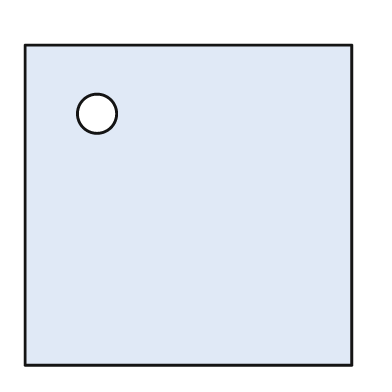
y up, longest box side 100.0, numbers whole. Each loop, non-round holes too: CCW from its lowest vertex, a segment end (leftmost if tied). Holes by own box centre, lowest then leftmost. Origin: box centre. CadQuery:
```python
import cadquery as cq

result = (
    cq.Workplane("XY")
    .moveTo(-50.0, -49.0)
    .lineTo(50.0, -49.0)
    .lineTo(50.0, 49.0)
    .lineTo(-50.0, 49.0)
    .close()
    .moveTo(-28.0, 28.0)
    .circle(6.0)
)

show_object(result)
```